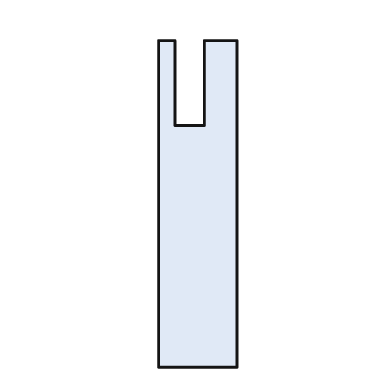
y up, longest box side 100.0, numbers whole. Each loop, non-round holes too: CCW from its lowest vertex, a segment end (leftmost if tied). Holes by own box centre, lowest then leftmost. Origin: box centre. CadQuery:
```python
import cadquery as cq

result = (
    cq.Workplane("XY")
    .moveTo(-12.0, -50.0)
    .lineTo(12.0, -50.0)
    .lineTo(12.0, 50.0)
    .lineTo(2.0, 50.0)
    .lineTo(2.0, 24.0)
    .lineTo(-7.0, 24.0)
    .lineTo(-7.0, 50.0)
    .lineTo(-12.0, 50.0)
    .close()
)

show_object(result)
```